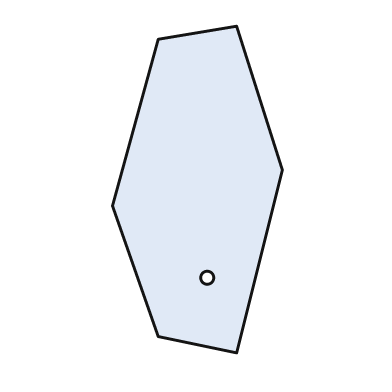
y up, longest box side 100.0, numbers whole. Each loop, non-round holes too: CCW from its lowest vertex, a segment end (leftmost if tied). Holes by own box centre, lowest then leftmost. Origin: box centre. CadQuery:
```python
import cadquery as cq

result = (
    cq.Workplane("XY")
    .moveTo(12.0, -50.0)
    .lineTo(26.0, 6.0)
    .lineTo(12.0, 50.0)
    .lineTo(-12.0, 46.0)
    .lineTo(-26.0, -5.0)
    .lineTo(-12.0, -45.0)
    .close()
    .moveTo(3.0, -27.0)
    .circle(2.0)
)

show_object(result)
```